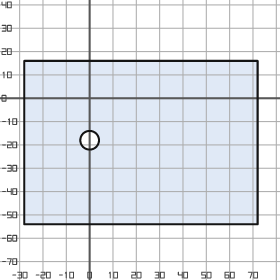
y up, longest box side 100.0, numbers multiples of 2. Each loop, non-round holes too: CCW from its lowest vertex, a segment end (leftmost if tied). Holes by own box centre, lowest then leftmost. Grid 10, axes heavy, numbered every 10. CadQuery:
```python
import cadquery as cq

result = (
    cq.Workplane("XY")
    .moveTo(-28.0, -54.0)
    .lineTo(72.0, -54.0)
    .lineTo(72.0, 16.0)
    .lineTo(-28.0, 16.0)
    .close()
    .moveTo(0.0, -18.0)
    .circle(4.0)
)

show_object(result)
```